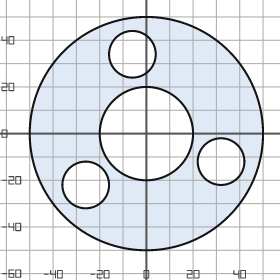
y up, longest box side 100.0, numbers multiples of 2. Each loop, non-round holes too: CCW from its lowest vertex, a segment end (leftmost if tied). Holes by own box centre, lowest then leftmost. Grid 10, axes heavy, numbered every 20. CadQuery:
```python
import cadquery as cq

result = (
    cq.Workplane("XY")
    .moveTo(0.0, 0.0)
    .circle(50.0)
    .moveTo(-26.0, -22.0)
    .circle(10.0)
    .moveTo(32.0, -12.0)
    .circle(10.0)
    .moveTo(0.0, 0.0)
    .circle(20.0)
    .moveTo(-6.0, 34.0)
    .circle(10.0)
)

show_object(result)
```